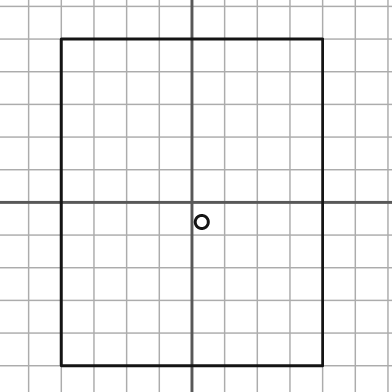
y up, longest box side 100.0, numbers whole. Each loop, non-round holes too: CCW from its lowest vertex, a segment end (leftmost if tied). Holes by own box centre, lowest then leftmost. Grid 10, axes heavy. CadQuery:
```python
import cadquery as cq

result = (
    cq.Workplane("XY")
    .moveTo(-40.0, -50.0)
    .lineTo(40.0, -50.0)
    .lineTo(40.0, 50.0)
    .lineTo(-40.0, 50.0)
    .close()
    .moveTo(3.0, -6.0)
    .circle(2.0)
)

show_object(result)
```